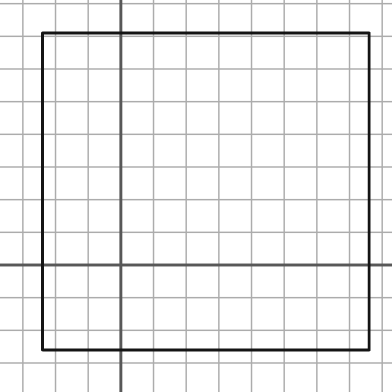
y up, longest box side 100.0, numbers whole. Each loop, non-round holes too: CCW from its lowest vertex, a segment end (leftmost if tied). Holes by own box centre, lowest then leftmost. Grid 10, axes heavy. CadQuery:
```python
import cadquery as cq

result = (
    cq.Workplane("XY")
    .moveTo(-24.0, -26.0)
    .lineTo(76.0, -26.0)
    .lineTo(76.0, 71.0)
    .lineTo(-24.0, 71.0)
    .close()
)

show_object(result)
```